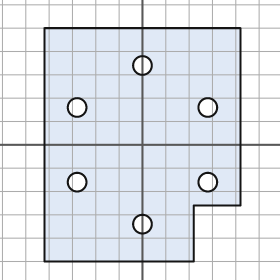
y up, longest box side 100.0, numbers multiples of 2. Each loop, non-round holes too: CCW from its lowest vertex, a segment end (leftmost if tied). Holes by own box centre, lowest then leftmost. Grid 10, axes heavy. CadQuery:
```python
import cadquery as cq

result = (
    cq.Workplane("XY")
    .moveTo(-42.0, -50.0)
    .lineTo(22.0, -50.0)
    .lineTo(22.0, -26.0)
    .lineTo(42.0, -26.0)
    .lineTo(42.0, 50.0)
    .lineTo(-42.0, 50.0)
    .close()
    .moveTo(0.0, -34.0)
    .circle(4.0)
    .moveTo(-28.0, -16.0)
    .circle(4.0)
    .moveTo(28.0, -16.0)
    .circle(4.0)
    .moveTo(-28.0, 16.0)
    .circle(4.0)
    .moveTo(28.0, 16.0)
    .circle(4.0)
    .moveTo(0.0, 34.0)
    .circle(4.0)
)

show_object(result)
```